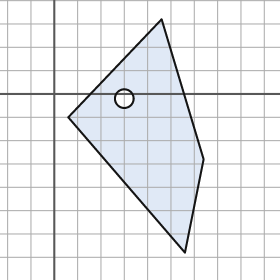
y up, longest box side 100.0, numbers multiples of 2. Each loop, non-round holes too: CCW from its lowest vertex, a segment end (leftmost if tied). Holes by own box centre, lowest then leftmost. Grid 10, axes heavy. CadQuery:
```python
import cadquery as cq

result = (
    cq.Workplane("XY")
    .moveTo(56.0, -68.0)
    .lineTo(64.0, -28.0)
    .lineTo(46.0, 32.0)
    .lineTo(6.0, -10.0)
    .close()
    .moveTo(30.0, -2.0)
    .circle(4.0)
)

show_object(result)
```